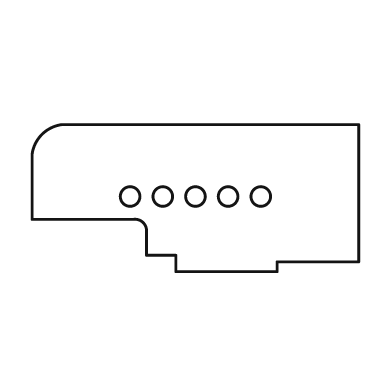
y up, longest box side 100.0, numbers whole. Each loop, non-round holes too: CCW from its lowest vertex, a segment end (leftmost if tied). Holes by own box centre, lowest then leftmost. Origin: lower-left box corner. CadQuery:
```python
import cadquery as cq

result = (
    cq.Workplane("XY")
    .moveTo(44.0, 0.0)
    .lineTo(75.0, 0.0)
    .lineTo(75.0, 3.0)
    .lineTo(100.0, 3.0)
    .lineTo(100.0, 45.0)
    .lineTo(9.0, 45.0)
    .threePointArc((3.0, 42.0), (0.0, 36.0))
    .lineTo(0.0, 16.0)
    .lineTo(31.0, 16.0)
    .threePointArc((34.0, 15.0), (35.0, 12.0))
    .lineTo(35.0, 5.0)
    .lineTo(44.0, 5.0)
    .close()
    .moveTo(30.0, 23.0)
    .circle(3.0)
    .moveTo(40.0, 23.0)
    .circle(3.0)
    .moveTo(50.0, 23.0)
    .circle(3.0)
    .moveTo(60.0, 23.0)
    .circle(3.0)
    .moveTo(70.0, 23.0)
    .circle(3.0)
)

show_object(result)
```